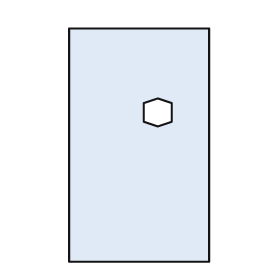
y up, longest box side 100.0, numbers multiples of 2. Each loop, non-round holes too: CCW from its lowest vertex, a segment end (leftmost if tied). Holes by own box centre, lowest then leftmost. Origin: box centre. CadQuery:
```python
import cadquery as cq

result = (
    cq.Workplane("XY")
    .moveTo(-30.0, -50.0)
    .lineTo(30.0, -50.0)
    .lineTo(30.0, 50.0)
    .lineTo(-30.0, 50.0)
    .close()
    .moveTo(8.0, 8.0)
    .lineTo(14.0, 10.0)
    .lineTo(14.0, 18.0)
    .lineTo(8.0, 20.0)
    .lineTo(2.0, 18.0)
    .lineTo(2.0, 10.0)
    .close()
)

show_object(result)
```